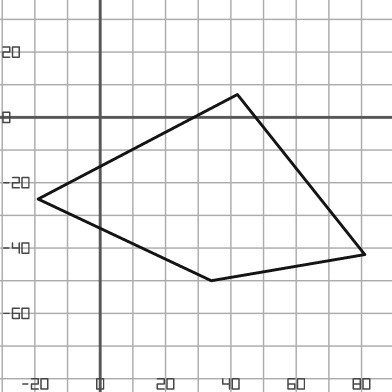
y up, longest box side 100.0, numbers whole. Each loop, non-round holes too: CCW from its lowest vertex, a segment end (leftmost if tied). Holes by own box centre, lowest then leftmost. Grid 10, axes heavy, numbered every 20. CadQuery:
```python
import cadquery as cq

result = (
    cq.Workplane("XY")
    .moveTo(34.0, -50.0)
    .lineTo(81.0, -42.0)
    .lineTo(42.0, 7.0)
    .lineTo(-19.0, -25.0)
    .close()
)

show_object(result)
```